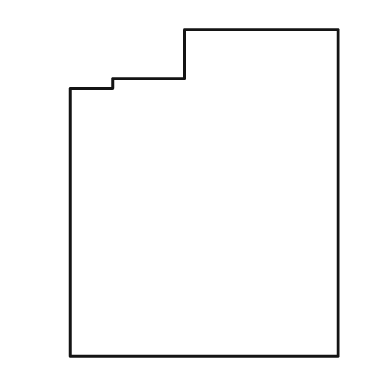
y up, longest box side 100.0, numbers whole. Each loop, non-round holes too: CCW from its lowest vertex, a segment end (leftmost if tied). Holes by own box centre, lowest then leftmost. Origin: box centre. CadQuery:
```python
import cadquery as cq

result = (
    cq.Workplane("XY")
    .moveTo(-41.0, -50.0)
    .lineTo(41.0, -50.0)
    .lineTo(41.0, 50.0)
    .lineTo(-6.0, 50.0)
    .lineTo(-6.0, 35.0)
    .lineTo(-28.0, 35.0)
    .lineTo(-28.0, 32.0)
    .lineTo(-41.0, 32.0)
    .close()
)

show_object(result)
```